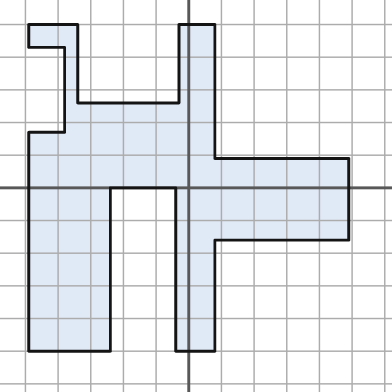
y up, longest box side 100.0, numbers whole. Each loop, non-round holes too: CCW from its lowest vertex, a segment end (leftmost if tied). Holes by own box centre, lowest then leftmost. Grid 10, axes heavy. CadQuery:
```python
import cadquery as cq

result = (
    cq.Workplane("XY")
    .moveTo(-49.0, -50.0)
    .lineTo(-24.0, -50.0)
    .lineTo(-24.0, 0.0)
    .lineTo(-4.0, 0.0)
    .lineTo(-4.0, -50.0)
    .lineTo(8.0, -50.0)
    .lineTo(8.0, -16.0)
    .lineTo(49.0, -16.0)
    .lineTo(49.0, 9.0)
    .lineTo(8.0, 9.0)
    .lineTo(8.0, 50.0)
    .lineTo(-3.0, 50.0)
    .lineTo(-3.0, 26.0)
    .lineTo(-34.0, 26.0)
    .lineTo(-34.0, 50.0)
    .lineTo(-49.0, 50.0)
    .lineTo(-49.0, 43.0)
    .lineTo(-38.0, 43.0)
    .lineTo(-38.0, 17.0)
    .lineTo(-49.0, 17.0)
    .close()
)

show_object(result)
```